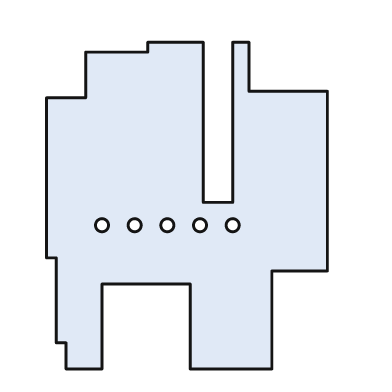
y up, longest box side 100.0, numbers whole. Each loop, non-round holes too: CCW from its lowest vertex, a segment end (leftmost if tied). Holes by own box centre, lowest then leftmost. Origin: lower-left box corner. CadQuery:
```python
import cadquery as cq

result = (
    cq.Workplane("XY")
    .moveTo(6.0, 0.0)
    .lineTo(17.0, 0.0)
    .lineTo(17.0, 26.0)
    .lineTo(44.0, 26.0)
    .lineTo(44.0, 0.0)
    .lineTo(69.0, 0.0)
    .lineTo(69.0, 30.0)
    .lineTo(86.0, 30.0)
    .lineTo(86.0, 85.0)
    .lineTo(62.0, 85.0)
    .lineTo(62.0, 100.0)
    .lineTo(57.0, 100.0)
    .lineTo(57.0, 51.0)
    .lineTo(48.0, 51.0)
    .lineTo(48.0, 100.0)
    .lineTo(31.0, 100.0)
    .lineTo(31.0, 97.0)
    .lineTo(12.0, 97.0)
    .lineTo(12.0, 83.0)
    .lineTo(0.0, 83.0)
    .lineTo(0.0, 34.0)
    .lineTo(3.0, 34.0)
    .lineTo(3.0, 8.0)
    .lineTo(6.0, 8.0)
    .close()
    .moveTo(17.0, 44.0)
    .circle(2.0)
    .moveTo(27.0, 44.0)
    .circle(2.0)
    .moveTo(37.0, 44.0)
    .circle(2.0)
    .moveTo(47.0, 44.0)
    .circle(2.0)
    .moveTo(57.0, 44.0)
    .circle(2.0)
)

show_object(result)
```